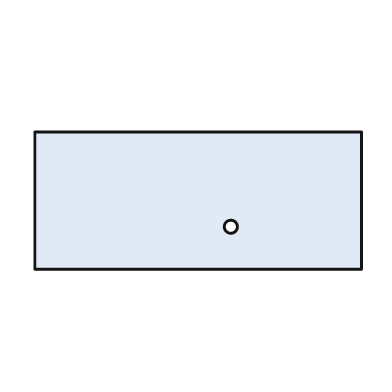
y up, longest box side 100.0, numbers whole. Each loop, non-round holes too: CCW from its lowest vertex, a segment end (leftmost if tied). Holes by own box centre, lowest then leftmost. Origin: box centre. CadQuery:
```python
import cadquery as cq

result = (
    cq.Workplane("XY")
    .moveTo(-50.0, -21.0)
    .lineTo(50.0, -21.0)
    .lineTo(50.0, 21.0)
    .lineTo(-50.0, 21.0)
    .close()
    .moveTo(10.0, -8.0)
    .circle(2.0)
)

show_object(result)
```